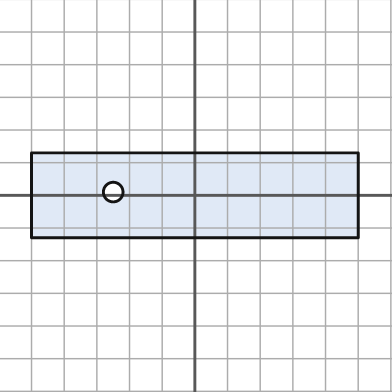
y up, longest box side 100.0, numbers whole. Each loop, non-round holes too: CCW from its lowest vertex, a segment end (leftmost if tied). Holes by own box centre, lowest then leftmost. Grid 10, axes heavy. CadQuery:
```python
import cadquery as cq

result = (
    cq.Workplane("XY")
    .moveTo(-50.0, -13.0)
    .lineTo(50.0, -13.0)
    .lineTo(50.0, 13.0)
    .lineTo(-50.0, 13.0)
    .close()
    .moveTo(-25.0, 1.0)
    .circle(3.0)
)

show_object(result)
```